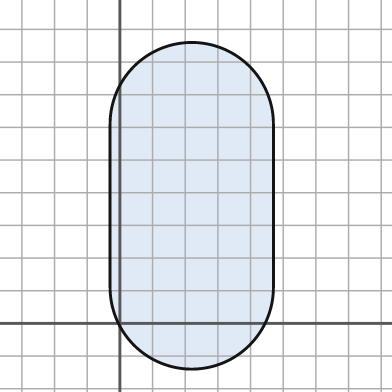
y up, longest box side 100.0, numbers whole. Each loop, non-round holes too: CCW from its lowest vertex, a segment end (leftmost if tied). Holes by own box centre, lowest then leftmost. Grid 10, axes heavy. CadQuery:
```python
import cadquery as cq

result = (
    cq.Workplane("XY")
    .moveTo(-3.0, 11.0)
    .threePointArc((22.0, -14.0), (47.0, 11.0))
    .lineTo(47.0, 61.0)
    .threePointArc((22.0, 86.0), (-3.0, 61.0))
    .close()
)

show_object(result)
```